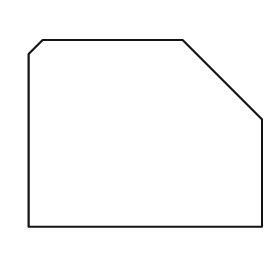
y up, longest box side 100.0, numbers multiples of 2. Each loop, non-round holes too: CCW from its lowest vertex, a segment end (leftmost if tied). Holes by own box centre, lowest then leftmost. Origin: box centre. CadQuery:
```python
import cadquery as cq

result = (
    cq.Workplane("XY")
    .moveTo(-50.0, -40.0)
    .lineTo(50.0, -40.0)
    .lineTo(50.0, 6.0)
    .lineTo(16.0, 40.0)
    .lineTo(-44.0, 40.0)
    .lineTo(-50.0, 34.0)
    .close()
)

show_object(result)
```